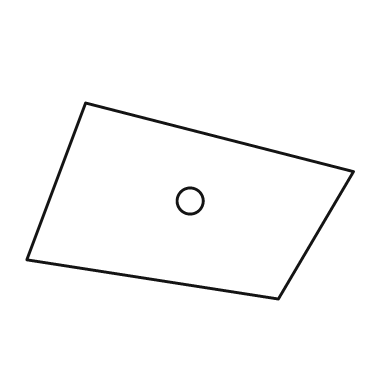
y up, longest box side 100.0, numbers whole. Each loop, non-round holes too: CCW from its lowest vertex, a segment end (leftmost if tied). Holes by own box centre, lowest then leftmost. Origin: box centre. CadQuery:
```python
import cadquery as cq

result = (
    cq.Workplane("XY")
    .moveTo(27.0, -30.0)
    .lineTo(50.0, 9.0)
    .lineTo(-32.0, 30.0)
    .lineTo(-50.0, -18.0)
    .close()
    .moveTo(0.0, 0.0)
    .circle(4.0)
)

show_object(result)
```